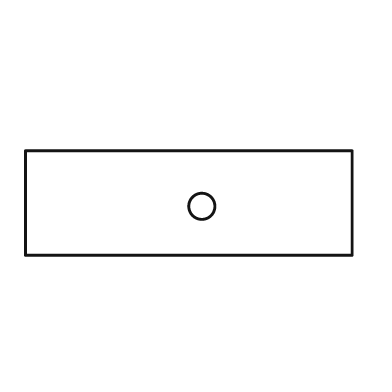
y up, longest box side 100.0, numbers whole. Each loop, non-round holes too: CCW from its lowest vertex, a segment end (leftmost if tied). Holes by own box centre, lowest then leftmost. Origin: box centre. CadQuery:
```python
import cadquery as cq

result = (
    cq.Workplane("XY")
    .moveTo(-50.0, -16.0)
    .lineTo(50.0, -16.0)
    .lineTo(50.0, 16.0)
    .lineTo(-50.0, 16.0)
    .close()
    .moveTo(4.0, -1.0)
    .circle(4.0)
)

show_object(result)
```